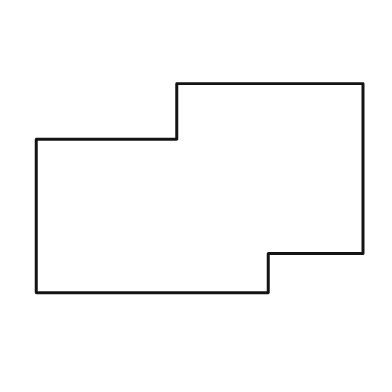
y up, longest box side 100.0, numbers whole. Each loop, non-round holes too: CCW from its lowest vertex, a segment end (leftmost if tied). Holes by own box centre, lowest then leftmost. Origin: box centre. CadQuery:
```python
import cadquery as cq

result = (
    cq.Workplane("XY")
    .moveTo(-50.0, -32.0)
    .lineTo(21.0, -32.0)
    .lineTo(21.0, -20.0)
    .lineTo(50.0, -20.0)
    .lineTo(50.0, 32.0)
    .lineTo(-7.0, 32.0)
    .lineTo(-7.0, 15.0)
    .lineTo(-50.0, 15.0)
    .close()
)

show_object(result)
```